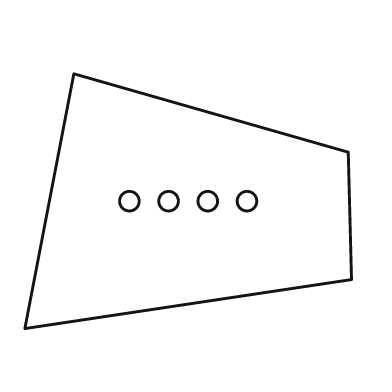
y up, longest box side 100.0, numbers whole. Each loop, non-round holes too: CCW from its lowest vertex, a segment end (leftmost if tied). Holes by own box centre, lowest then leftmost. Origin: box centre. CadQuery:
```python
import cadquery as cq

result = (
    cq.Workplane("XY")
    .moveTo(-50.0, -39.0)
    .lineTo(50.0, -24.0)
    .lineTo(49.0, 15.0)
    .lineTo(-35.0, 39.0)
    .close()
    .moveTo(-18.0, 0.0)
    .circle(3.0)
    .moveTo(-6.0, 0.0)
    .circle(3.0)
    .moveTo(6.0, 0.0)
    .circle(3.0)
    .moveTo(18.0, 0.0)
    .circle(3.0)
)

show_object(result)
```